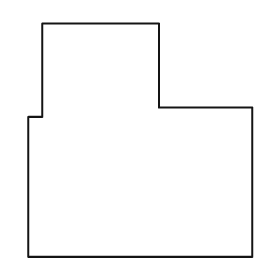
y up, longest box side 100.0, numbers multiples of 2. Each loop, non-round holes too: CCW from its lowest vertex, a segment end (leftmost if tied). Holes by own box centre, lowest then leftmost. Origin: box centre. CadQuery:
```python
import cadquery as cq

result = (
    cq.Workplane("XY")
    .moveTo(-48.0, -50.0)
    .lineTo(48.0, -50.0)
    .lineTo(48.0, 14.0)
    .lineTo(8.0, 14.0)
    .lineTo(8.0, 50.0)
    .lineTo(-42.0, 50.0)
    .lineTo(-42.0, 10.0)
    .lineTo(-48.0, 10.0)
    .close()
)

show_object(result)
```